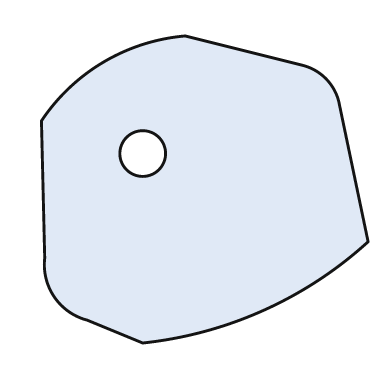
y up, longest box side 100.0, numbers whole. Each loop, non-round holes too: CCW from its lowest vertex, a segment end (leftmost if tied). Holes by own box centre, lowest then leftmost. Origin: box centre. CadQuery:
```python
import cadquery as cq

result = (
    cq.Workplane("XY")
    .moveTo(-19.0, -47.0)
    .threePointArc((18.0, -37.0), (50.0, -16.0))
    .lineTo(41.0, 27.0)
    .threePointArc((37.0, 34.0), (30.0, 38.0))
    .lineTo(-6.0, 47.0)
    .threePointArc((-31.0, 39.0), (-50.0, 21.0))
    .lineTo(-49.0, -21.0)
    .threePointArc((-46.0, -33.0), (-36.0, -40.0))
    .close()
    .moveTo(-19.0, 11.0)
    .circle(7.0)
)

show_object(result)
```